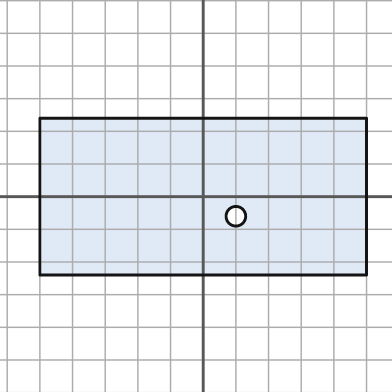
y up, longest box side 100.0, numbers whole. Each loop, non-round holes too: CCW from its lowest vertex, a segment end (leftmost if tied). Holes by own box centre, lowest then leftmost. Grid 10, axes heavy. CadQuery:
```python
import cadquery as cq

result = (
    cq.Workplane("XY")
    .moveTo(-50.0, -24.0)
    .lineTo(50.0, -24.0)
    .lineTo(50.0, 24.0)
    .lineTo(-50.0, 24.0)
    .close()
    .moveTo(10.0, -6.0)
    .circle(3.0)
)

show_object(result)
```